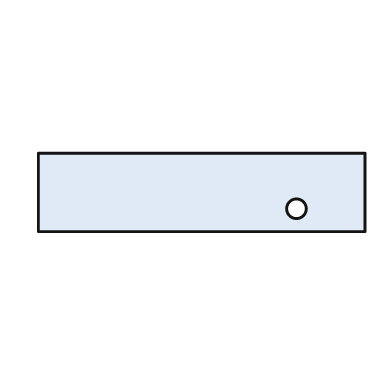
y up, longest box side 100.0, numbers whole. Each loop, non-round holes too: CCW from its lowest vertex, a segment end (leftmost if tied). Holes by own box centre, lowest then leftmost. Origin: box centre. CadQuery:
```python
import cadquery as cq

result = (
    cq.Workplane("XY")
    .moveTo(-50.0, -12.0)
    .lineTo(50.0, -12.0)
    .lineTo(50.0, 12.0)
    .lineTo(-50.0, 12.0)
    .close()
    .moveTo(29.0, -5.0)
    .circle(3.0)
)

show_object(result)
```